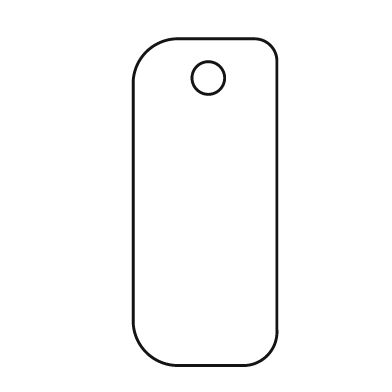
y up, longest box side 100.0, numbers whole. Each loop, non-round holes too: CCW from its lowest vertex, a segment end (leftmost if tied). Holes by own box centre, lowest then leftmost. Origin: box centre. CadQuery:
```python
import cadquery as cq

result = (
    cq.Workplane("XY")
    .moveTo(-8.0, -50.0)
    .lineTo(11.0, -50.0)
    .threePointArc((19.0, -47.0), (22.0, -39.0))
    .lineTo(22.0, 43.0)
    .threePointArc((20.0, 48.0), (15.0, 50.0))
    .lineTo(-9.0, 50.0)
    .threePointArc((-18.0, 46.0), (-22.0, 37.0))
    .lineTo(-22.0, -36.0)
    .threePointArc((-18.0, -46.0), (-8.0, -50.0))
    .close()
    .moveTo(1.0, 38.0)
    .circle(5.0)
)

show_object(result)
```